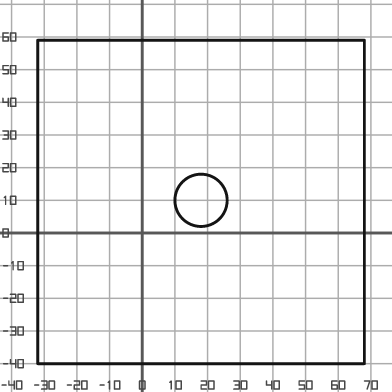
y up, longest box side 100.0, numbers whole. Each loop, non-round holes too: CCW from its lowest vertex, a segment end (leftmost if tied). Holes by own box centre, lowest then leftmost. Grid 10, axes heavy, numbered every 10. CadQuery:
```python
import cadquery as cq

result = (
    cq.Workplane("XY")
    .moveTo(-32.0, -40.0)
    .lineTo(68.0, -40.0)
    .lineTo(68.0, 59.0)
    .lineTo(-32.0, 59.0)
    .close()
    .moveTo(18.0, 10.0)
    .circle(8.0)
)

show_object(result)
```